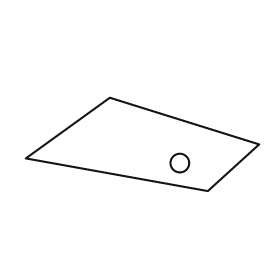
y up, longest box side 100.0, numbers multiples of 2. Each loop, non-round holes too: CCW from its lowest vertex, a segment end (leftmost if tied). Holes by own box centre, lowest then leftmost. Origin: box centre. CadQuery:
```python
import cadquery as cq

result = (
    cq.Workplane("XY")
    .moveTo(28.0, -20.0)
    .lineTo(50.0, 0.0)
    .lineTo(-14.0, 20.0)
    .lineTo(-50.0, -6.0)
    .close()
    .moveTo(16.0, -8.0)
    .circle(4.0)
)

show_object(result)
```